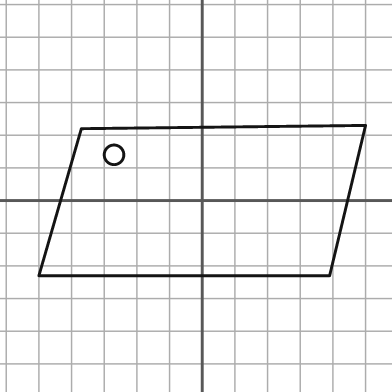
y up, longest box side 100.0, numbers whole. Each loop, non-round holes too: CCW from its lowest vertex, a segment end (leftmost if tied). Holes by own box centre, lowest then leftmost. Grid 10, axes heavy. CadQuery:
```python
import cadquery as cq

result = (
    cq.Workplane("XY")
    .moveTo(-50.0, -23.0)
    .lineTo(39.0, -23.0)
    .lineTo(50.0, 23.0)
    .lineTo(-37.0, 22.0)
    .close()
    .moveTo(-27.0, 14.0)
    .circle(3.0)
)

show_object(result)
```